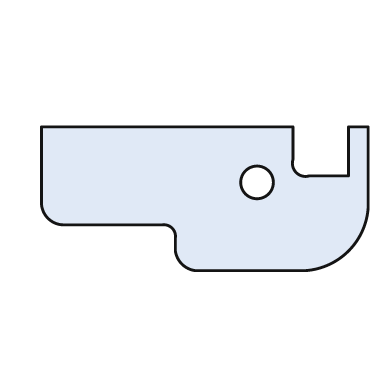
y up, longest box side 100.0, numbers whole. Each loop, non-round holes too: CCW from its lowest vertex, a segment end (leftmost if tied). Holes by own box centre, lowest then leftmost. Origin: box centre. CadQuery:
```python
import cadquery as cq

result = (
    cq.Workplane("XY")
    .moveTo(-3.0, -22.0)
    .lineTo(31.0, -22.0)
    .threePointArc((44.0, -16.0), (50.0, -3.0))
    .lineTo(50.0, 22.0)
    .lineTo(44.0, 22.0)
    .lineTo(44.0, 7.0)
    .lineTo(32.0, 7.0)
    .threePointArc((28.0, 8.0), (27.0, 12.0))
    .lineTo(27.0, 22.0)
    .lineTo(-50.0, 22.0)
    .lineTo(-50.0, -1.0)
    .threePointArc((-48.0, -6.0), (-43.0, -8.0))
    .lineTo(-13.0, -8.0)
    .threePointArc((-10.0, -9.0), (-9.0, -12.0))
    .lineTo(-9.0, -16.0)
    .threePointArc((-7.0, -20.0), (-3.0, -22.0))
    .close()
    .moveTo(16.0, 5.0)
    .circle(5.0)
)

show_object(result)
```